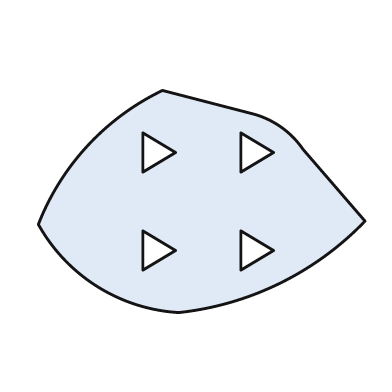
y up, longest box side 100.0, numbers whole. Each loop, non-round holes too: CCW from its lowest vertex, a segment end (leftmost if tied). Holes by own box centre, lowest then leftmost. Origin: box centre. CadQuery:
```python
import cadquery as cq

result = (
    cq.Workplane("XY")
    .moveTo(-7.0, -34.0)
    .threePointArc((24.0, -25.0), (50.0, -6.0))
    .lineTo(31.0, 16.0)
    .threePointArc((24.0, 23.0), (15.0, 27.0))
    .lineTo(-12.0, 34.0)
    .threePointArc((-35.0, 17.0), (-50.0, -7.0))
    .threePointArc((-32.0, -26.0), (-7.0, -34.0))
    .close()
    .moveTo(-18.0, -21.0)
    .lineTo(-8.0, -15.0)
    .lineTo(-18.0, -9.0)
    .close()
    .moveTo(12.0, -21.0)
    .lineTo(22.0, -15.0)
    .lineTo(12.0, -9.0)
    .close()
    .moveTo(-18.0, 9.0)
    .lineTo(-8.0, 15.0)
    .lineTo(-18.0, 21.0)
    .close()
    .moveTo(12.0, 9.0)
    .lineTo(22.0, 15.0)
    .lineTo(12.0, 21.0)
    .close()
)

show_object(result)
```